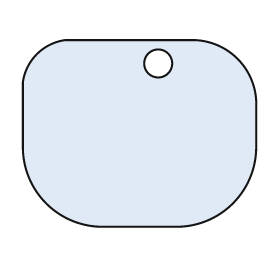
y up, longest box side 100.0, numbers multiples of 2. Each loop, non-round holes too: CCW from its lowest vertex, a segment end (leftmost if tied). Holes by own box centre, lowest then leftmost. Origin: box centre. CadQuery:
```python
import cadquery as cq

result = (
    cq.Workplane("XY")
    .moveTo(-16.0, -40.0)
    .lineTo(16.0, -40.0)
    .threePointArc((40.0, -30.0), (50.0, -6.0))
    .lineTo(50.0, 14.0)
    .threePointArc((42.0, 32.0), (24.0, 40.0))
    .lineTo(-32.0, 40.0)
    .threePointArc((-44.0, 34.0), (-50.0, 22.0))
    .lineTo(-50.0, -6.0)
    .threePointArc((-40.0, -30.0), (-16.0, -40.0))
    .close()
    .moveTo(8.0, 30.0)
    .circle(6.0)
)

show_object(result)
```